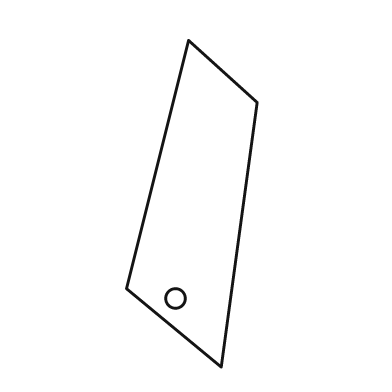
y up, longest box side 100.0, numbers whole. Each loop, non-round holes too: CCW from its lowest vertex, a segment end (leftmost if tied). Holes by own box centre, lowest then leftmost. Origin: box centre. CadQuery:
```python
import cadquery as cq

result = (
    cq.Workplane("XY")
    .moveTo(9.0, -50.0)
    .lineTo(20.0, 31.0)
    .lineTo(-1.0, 50.0)
    .lineTo(-20.0, -26.0)
    .close()
    .moveTo(-5.0, -29.0)
    .circle(3.0)
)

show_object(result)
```